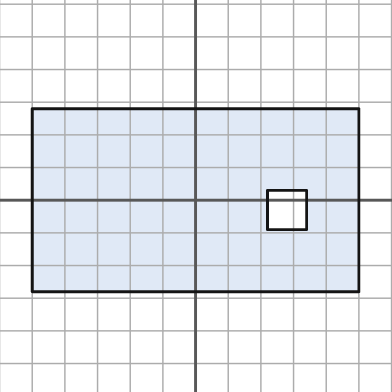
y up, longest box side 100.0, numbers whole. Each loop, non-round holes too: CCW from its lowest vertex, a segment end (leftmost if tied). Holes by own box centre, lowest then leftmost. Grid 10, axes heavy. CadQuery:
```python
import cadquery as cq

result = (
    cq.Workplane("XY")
    .moveTo(-50.0, -28.0)
    .lineTo(50.0, -28.0)
    .lineTo(50.0, 28.0)
    .lineTo(-50.0, 28.0)
    .close()
    .moveTo(22.0, -9.0)
    .lineTo(34.0, -9.0)
    .lineTo(34.0, 3.0)
    .lineTo(22.0, 3.0)
    .close()
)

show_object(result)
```